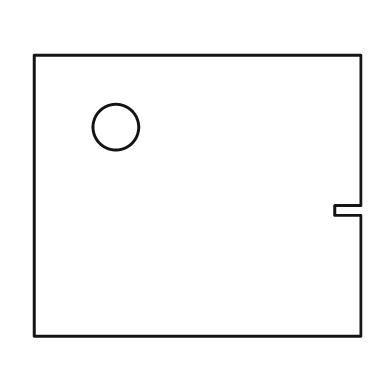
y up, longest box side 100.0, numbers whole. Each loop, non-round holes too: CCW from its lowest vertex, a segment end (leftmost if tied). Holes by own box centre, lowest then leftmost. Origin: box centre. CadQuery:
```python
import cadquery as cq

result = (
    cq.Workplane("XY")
    .moveTo(-50.0, -43.0)
    .lineTo(50.0, -43.0)
    .lineTo(50.0, -6.0)
    .lineTo(42.0, -6.0)
    .lineTo(42.0, -3.0)
    .lineTo(50.0, -3.0)
    .lineTo(50.0, 43.0)
    .lineTo(-50.0, 43.0)
    .close()
    .moveTo(-25.0, 21.0)
    .circle(7.0)
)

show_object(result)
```